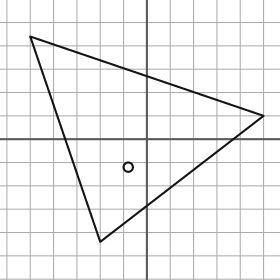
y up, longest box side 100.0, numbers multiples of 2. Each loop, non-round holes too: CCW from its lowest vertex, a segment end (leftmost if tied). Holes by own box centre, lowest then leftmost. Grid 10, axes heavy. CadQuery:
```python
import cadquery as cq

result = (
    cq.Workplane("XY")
    .moveTo(-20.0, -44.0)
    .lineTo(50.0, 10.0)
    .lineTo(-50.0, 44.0)
    .close()
    .moveTo(-8.0, -12.0)
    .circle(2.0)
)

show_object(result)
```